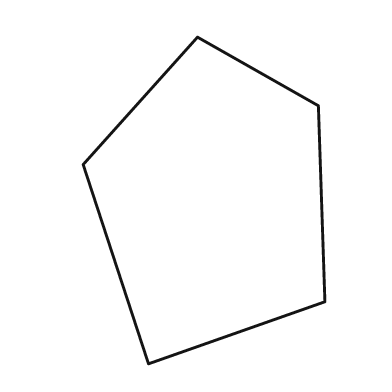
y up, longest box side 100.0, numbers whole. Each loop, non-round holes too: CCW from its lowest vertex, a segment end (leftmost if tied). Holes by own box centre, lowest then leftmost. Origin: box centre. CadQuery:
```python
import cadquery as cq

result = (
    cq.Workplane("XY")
    .moveTo(-17.0, -50.0)
    .lineTo(37.0, -31.0)
    .lineTo(35.0, 29.0)
    .lineTo(-2.0, 50.0)
    .lineTo(-37.0, 11.0)
    .close()
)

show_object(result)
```